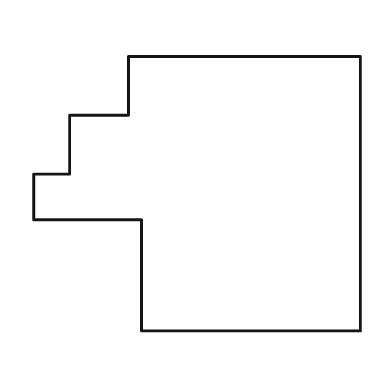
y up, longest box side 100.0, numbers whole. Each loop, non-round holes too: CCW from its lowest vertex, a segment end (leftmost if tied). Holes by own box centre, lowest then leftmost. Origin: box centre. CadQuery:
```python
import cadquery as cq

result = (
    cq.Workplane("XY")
    .moveTo(-17.0, -42.0)
    .lineTo(50.0, -42.0)
    .lineTo(50.0, 42.0)
    .lineTo(-21.0, 42.0)
    .lineTo(-21.0, 24.0)
    .lineTo(-39.0, 24.0)
    .lineTo(-39.0, 6.0)
    .lineTo(-50.0, 6.0)
    .lineTo(-50.0, -8.0)
    .lineTo(-17.0, -8.0)
    .close()
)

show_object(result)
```